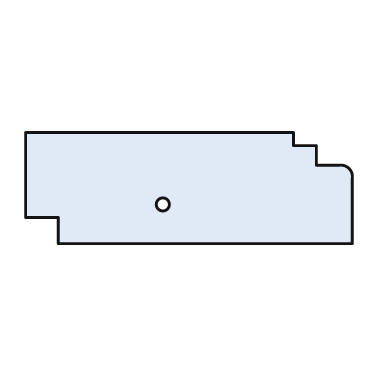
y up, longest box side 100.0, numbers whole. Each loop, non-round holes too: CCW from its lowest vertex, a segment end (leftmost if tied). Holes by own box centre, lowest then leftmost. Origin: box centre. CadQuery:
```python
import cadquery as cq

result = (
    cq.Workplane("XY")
    .moveTo(-40.0, -17.0)
    .lineTo(50.0, -17.0)
    .lineTo(50.0, 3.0)
    .threePointArc((49.0, 6.0), (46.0, 7.0))
    .lineTo(39.0, 7.0)
    .lineTo(39.0, 13.0)
    .lineTo(32.0, 13.0)
    .lineTo(32.0, 17.0)
    .lineTo(-50.0, 17.0)
    .lineTo(-50.0, -9.0)
    .lineTo(-40.0, -9.0)
    .close()
    .moveTo(-8.0, -5.0)
    .circle(2.0)
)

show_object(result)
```